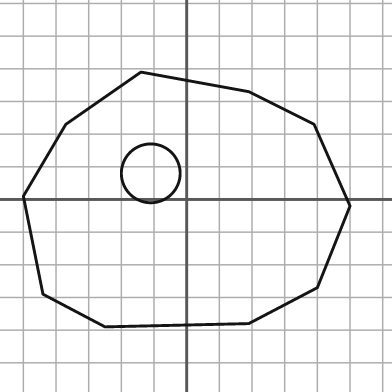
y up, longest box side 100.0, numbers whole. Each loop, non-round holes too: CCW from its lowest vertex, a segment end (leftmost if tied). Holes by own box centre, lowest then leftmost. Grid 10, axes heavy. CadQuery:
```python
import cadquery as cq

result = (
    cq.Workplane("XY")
    .moveTo(-25.0, -39.0)
    .lineTo(19.0, -38.0)
    .lineTo(40.0, -27.0)
    .lineTo(50.0, -2.0)
    .lineTo(39.0, 23.0)
    .lineTo(19.0, 33.0)
    .lineTo(-14.0, 39.0)
    .lineTo(-37.0, 23.0)
    .lineTo(-50.0, 1.0)
    .lineTo(-44.0, -29.0)
    .close()
    .moveTo(-11.0, 8.0)
    .circle(9.0)
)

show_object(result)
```